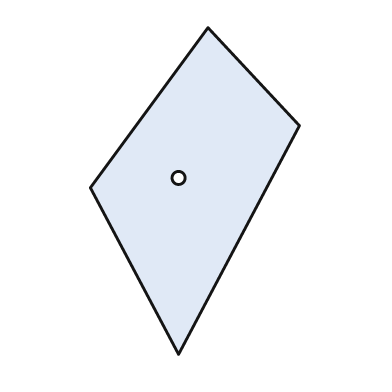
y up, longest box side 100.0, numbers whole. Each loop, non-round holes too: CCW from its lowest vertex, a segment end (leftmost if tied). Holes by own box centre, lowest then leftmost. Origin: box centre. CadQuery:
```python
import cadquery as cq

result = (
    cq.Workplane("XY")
    .moveTo(-5.0, -50.0)
    .lineTo(32.0, 20.0)
    .lineTo(4.0, 50.0)
    .lineTo(-32.0, 1.0)
    .close()
    .moveTo(-5.0, 4.0)
    .circle(2.0)
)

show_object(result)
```